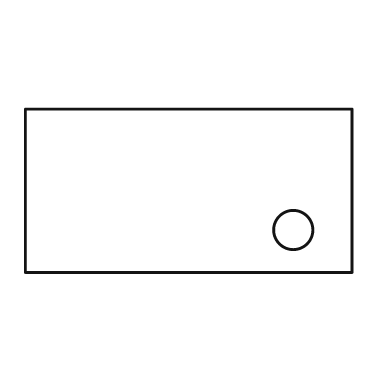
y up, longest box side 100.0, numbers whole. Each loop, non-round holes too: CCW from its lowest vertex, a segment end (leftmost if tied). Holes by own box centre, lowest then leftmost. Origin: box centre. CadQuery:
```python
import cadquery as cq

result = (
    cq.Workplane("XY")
    .moveTo(-50.0, -25.0)
    .lineTo(50.0, -25.0)
    .lineTo(50.0, 25.0)
    .lineTo(-50.0, 25.0)
    .close()
    .moveTo(32.0, -12.0)
    .circle(6.0)
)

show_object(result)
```